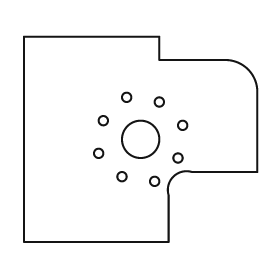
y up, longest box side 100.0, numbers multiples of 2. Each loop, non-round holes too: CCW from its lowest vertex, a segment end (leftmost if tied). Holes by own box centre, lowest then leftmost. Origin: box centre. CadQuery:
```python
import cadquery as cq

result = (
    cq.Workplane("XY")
    .moveTo(-50.0, -44.0)
    .lineTo(12.0, -44.0)
    .lineTo(12.0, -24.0)
    .threePointArc((14.0, -16.0), (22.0, -14.0))
    .lineTo(50.0, -14.0)
    .lineTo(50.0, 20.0)
    .threePointArc((46.0, 30.0), (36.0, 34.0))
    .lineTo(8.0, 34.0)
    .lineTo(8.0, 44.0)
    .lineTo(-50.0, 44.0)
    .close()
    .moveTo(6.0, -18.0)
    .circle(2.0)
    .moveTo(-8.0, -16.0)
    .circle(2.0)
    .moveTo(16.0, -8.0)
    .circle(2.0)
    .moveTo(-18.0, -6.0)
    .circle(2.0)
    .moveTo(0.0, 0.0)
    .circle(8.0)
    .moveTo(18.0, 6.0)
    .circle(2.0)
    .moveTo(-16.0, 8.0)
    .circle(2.0)
    .moveTo(8.0, 16.0)
    .circle(2.0)
    .moveTo(-6.0, 18.0)
    .circle(2.0)
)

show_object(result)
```